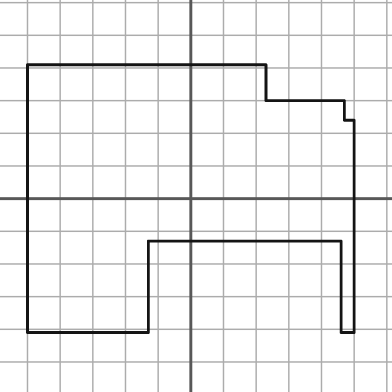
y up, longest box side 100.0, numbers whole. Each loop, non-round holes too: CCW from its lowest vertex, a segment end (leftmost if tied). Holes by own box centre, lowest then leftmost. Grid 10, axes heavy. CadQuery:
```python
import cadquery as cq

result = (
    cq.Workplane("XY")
    .moveTo(-50.0, -41.0)
    .lineTo(-13.0, -41.0)
    .lineTo(-13.0, -13.0)
    .lineTo(46.0, -13.0)
    .lineTo(46.0, -41.0)
    .lineTo(50.0, -41.0)
    .lineTo(50.0, 24.0)
    .lineTo(47.0, 24.0)
    .lineTo(47.0, 30.0)
    .lineTo(23.0, 30.0)
    .lineTo(23.0, 41.0)
    .lineTo(-50.0, 41.0)
    .close()
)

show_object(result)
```